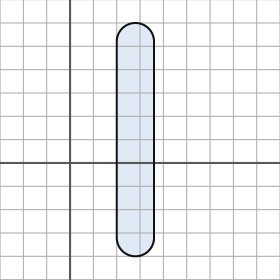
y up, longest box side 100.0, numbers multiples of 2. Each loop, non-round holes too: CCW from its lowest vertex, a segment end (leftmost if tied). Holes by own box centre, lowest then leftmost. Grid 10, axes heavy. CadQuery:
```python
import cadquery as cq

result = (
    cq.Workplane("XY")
    .moveTo(20.0, -32.0)
    .threePointArc((28.0, -40.0), (36.0, -32.0))
    .lineTo(36.0, 52.0)
    .threePointArc((28.0, 60.0), (20.0, 52.0))
    .close()
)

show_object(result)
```